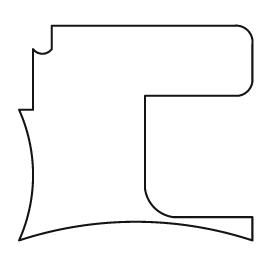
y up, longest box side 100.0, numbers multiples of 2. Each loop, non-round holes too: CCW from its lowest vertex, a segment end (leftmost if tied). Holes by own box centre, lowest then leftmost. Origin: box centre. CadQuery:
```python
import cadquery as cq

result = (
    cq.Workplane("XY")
    .moveTo(-50.0, -46.0)
    .threePointArc((0.0, -38.0), (50.0, -46.0))
    .lineTo(50.0, -36.0)
    .lineTo(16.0, -36.0)
    .threePointArc((8.0, -32.0), (4.0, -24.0))
    .lineTo(4.0, 16.0)
    .lineTo(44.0, 16.0)
    .threePointArc((48.0, 18.0), (50.0, 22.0))
    .lineTo(50.0, 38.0)
    .threePointArc((48.0, 44.0), (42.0, 46.0))
    .lineTo(-36.0, 46.0)
    .lineTo(-36.0, 36.0)
    .threePointArc((-40.0, 34.0), (-44.0, 36.0))
    .lineTo(-44.0, 10.0)
    .lineTo(-50.0, 10.0)
    .threePointArc((-44.0, -18.0), (-50.0, -46.0))
    .close()
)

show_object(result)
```